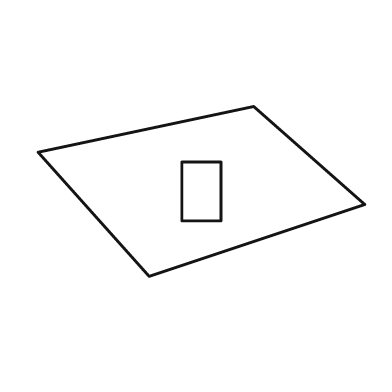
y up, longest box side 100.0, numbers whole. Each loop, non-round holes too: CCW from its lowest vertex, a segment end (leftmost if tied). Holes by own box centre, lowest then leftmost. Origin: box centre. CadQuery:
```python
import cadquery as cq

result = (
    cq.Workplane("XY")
    .moveTo(-16.0, -26.0)
    .lineTo(50.0, -4.0)
    .lineTo(16.0, 26.0)
    .lineTo(-50.0, 12.0)
    .close()
    .moveTo(-6.0, -9.0)
    .lineTo(6.0, -9.0)
    .lineTo(6.0, 9.0)
    .lineTo(-6.0, 9.0)
    .close()
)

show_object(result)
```